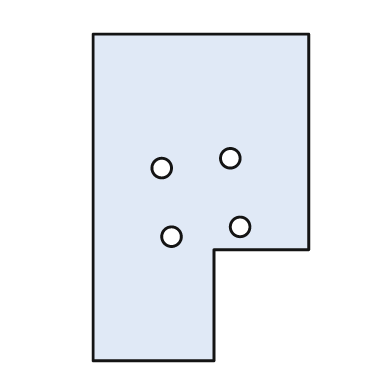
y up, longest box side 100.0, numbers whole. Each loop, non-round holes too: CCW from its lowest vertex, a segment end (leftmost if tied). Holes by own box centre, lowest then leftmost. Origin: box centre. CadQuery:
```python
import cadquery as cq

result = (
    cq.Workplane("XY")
    .moveTo(-33.0, -50.0)
    .lineTo(4.0, -50.0)
    .lineTo(4.0, -16.0)
    .lineTo(33.0, -16.0)
    .lineTo(33.0, 50.0)
    .lineTo(-33.0, 50.0)
    .close()
    .moveTo(-9.0, -12.0)
    .circle(3.0)
    .moveTo(12.0, -9.0)
    .circle(3.0)
    .moveTo(-12.0, 9.0)
    .circle(3.0)
    .moveTo(9.0, 12.0)
    .circle(3.0)
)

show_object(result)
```